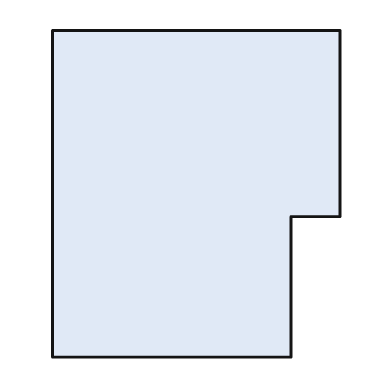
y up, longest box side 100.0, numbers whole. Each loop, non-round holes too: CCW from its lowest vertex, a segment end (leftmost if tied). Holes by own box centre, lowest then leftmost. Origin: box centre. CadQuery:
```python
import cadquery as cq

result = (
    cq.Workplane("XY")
    .moveTo(-44.0, -50.0)
    .lineTo(29.0, -50.0)
    .lineTo(29.0, -7.0)
    .lineTo(44.0, -7.0)
    .lineTo(44.0, 50.0)
    .lineTo(-44.0, 50.0)
    .close()
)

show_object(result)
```